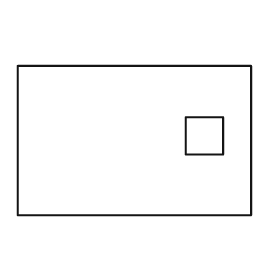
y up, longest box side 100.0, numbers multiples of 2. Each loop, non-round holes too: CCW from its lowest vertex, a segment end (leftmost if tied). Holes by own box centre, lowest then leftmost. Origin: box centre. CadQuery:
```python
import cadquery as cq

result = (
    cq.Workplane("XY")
    .moveTo(-50.0, -32.0)
    .lineTo(50.0, -32.0)
    .lineTo(50.0, 32.0)
    .lineTo(-50.0, 32.0)
    .close()
    .moveTo(22.0, -6.0)
    .lineTo(38.0, -6.0)
    .lineTo(38.0, 10.0)
    .lineTo(22.0, 10.0)
    .close()
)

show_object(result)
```